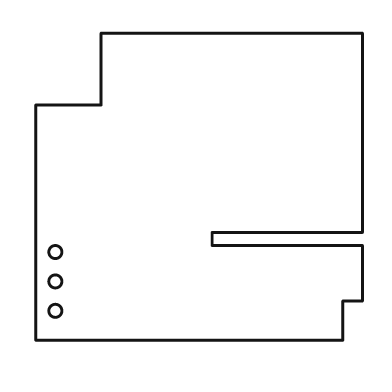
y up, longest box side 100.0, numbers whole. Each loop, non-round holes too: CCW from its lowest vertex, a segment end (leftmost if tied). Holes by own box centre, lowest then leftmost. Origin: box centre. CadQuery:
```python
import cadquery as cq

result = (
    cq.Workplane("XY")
    .moveTo(-50.0, -47.0)
    .lineTo(44.0, -47.0)
    .lineTo(44.0, -35.0)
    .lineTo(50.0, -35.0)
    .lineTo(50.0, -18.0)
    .lineTo(4.0, -18.0)
    .lineTo(4.0, -14.0)
    .lineTo(50.0, -14.0)
    .lineTo(50.0, 47.0)
    .lineTo(-30.0, 47.0)
    .lineTo(-30.0, 25.0)
    .lineTo(-50.0, 25.0)
    .close()
    .moveTo(-44.0, -38.0)
    .circle(2.0)
    .moveTo(-44.0, -29.0)
    .circle(2.0)
    .moveTo(-44.0, -20.0)
    .circle(2.0)
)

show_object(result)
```